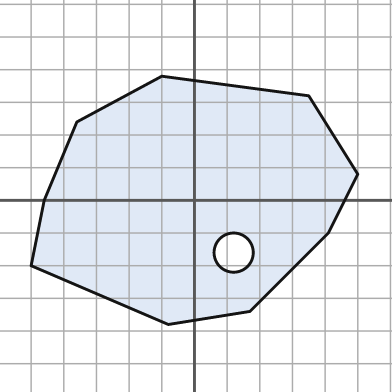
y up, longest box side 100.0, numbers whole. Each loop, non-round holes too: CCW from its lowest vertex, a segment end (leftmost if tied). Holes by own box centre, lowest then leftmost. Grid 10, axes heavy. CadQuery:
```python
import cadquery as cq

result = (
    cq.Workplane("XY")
    .moveTo(-8.0, -38.0)
    .lineTo(17.0, -34.0)
    .lineTo(41.0, -10.0)
    .lineTo(50.0, 8.0)
    .lineTo(35.0, 32.0)
    .lineTo(-10.0, 38.0)
    .lineTo(-36.0, 24.0)
    .lineTo(-46.0, 0.0)
    .lineTo(-50.0, -20.0)
    .close()
    .moveTo(12.0, -16.0)
    .circle(6.0)
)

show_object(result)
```